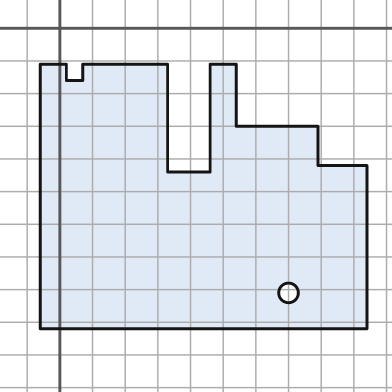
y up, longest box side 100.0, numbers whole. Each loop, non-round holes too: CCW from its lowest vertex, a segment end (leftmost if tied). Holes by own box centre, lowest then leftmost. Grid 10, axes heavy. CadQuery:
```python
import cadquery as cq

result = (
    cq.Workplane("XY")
    .moveTo(-6.0, -92.0)
    .lineTo(94.0, -92.0)
    .lineTo(94.0, -42.0)
    .lineTo(79.0, -42.0)
    .lineTo(79.0, -30.0)
    .lineTo(54.0, -30.0)
    .lineTo(54.0, -11.0)
    .lineTo(46.0, -11.0)
    .lineTo(46.0, -44.0)
    .lineTo(33.0, -44.0)
    .lineTo(33.0, -11.0)
    .lineTo(7.0, -11.0)
    .lineTo(7.0, -16.0)
    .lineTo(2.0, -16.0)
    .lineTo(2.0, -11.0)
    .lineTo(-6.0, -11.0)
    .close()
    .moveTo(70.0, -81.0)
    .circle(3.0)
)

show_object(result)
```